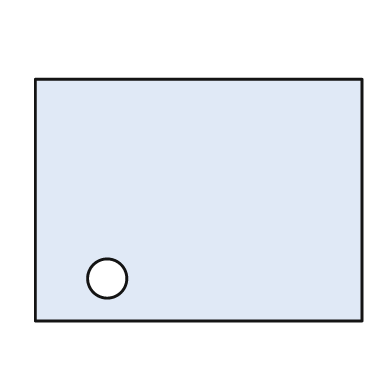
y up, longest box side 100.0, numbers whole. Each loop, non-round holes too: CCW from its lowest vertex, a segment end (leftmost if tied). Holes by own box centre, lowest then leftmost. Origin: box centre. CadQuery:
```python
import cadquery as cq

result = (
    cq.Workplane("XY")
    .moveTo(-50.0, -37.0)
    .lineTo(50.0, -37.0)
    .lineTo(50.0, 37.0)
    .lineTo(-50.0, 37.0)
    .close()
    .moveTo(-28.0, -24.0)
    .circle(6.0)
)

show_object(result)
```